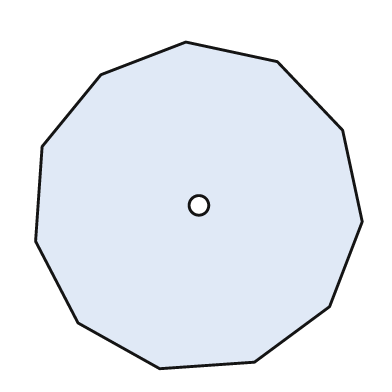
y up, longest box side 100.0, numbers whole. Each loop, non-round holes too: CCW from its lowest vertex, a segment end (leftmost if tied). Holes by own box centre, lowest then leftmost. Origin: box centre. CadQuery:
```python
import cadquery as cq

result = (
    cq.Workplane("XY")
    .moveTo(-12.0, -50.0)
    .lineTo(17.0, -48.0)
    .lineTo(40.0, -31.0)
    .lineTo(50.0, -5.0)
    .lineTo(44.0, 23.0)
    .lineTo(24.0, 44.0)
    .lineTo(-4.0, 50.0)
    .lineTo(-30.0, 40.0)
    .lineTo(-48.0, 18.0)
    .lineTo(-50.0, -11.0)
    .lineTo(-37.0, -36.0)
    .close()
    .moveTo(0.0, 0.0)
    .circle(3.0)
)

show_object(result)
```